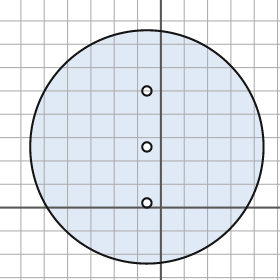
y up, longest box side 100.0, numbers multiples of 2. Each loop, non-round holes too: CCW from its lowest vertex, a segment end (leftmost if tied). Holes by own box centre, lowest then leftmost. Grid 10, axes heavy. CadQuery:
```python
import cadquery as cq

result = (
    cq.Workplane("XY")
    .moveTo(-6.0, 26.0)
    .circle(50.0)
    .moveTo(-6.0, 2.0)
    .circle(2.0)
    .moveTo(-6.0, 26.0)
    .circle(2.0)
    .moveTo(-6.0, 50.0)
    .circle(2.0)
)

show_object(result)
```